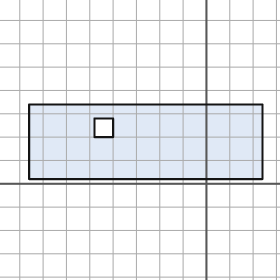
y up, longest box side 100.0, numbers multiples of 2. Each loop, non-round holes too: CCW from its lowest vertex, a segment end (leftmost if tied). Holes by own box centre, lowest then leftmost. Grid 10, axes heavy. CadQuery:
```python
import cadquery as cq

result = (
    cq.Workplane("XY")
    .moveTo(-76.0, 2.0)
    .lineTo(24.0, 2.0)
    .lineTo(24.0, 34.0)
    .lineTo(-76.0, 34.0)
    .close()
    .moveTo(-48.0, 20.0)
    .lineTo(-40.0, 20.0)
    .lineTo(-40.0, 28.0)
    .lineTo(-48.0, 28.0)
    .close()
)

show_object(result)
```